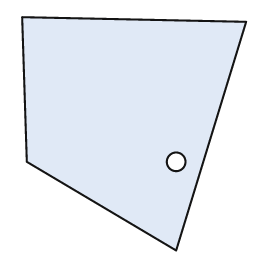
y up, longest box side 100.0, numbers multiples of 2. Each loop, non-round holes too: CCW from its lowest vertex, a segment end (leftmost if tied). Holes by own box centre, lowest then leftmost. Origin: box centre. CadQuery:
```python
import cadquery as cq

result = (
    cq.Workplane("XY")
    .moveTo(18.0, -50.0)
    .lineTo(48.0, 48.0)
    .lineTo(-48.0, 50.0)
    .lineTo(-46.0, -12.0)
    .close()
    .moveTo(18.0, -12.0)
    .circle(4.0)
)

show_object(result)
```